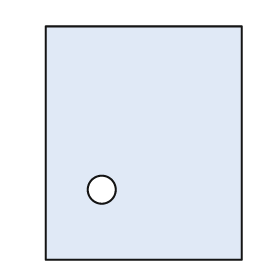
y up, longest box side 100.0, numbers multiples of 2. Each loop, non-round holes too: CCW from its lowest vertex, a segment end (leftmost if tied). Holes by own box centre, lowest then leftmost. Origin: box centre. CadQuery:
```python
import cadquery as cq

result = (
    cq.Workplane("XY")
    .moveTo(-42.0, -50.0)
    .lineTo(42.0, -50.0)
    .lineTo(42.0, 50.0)
    .lineTo(-42.0, 50.0)
    .close()
    .moveTo(-18.0, -20.0)
    .circle(6.0)
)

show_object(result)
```